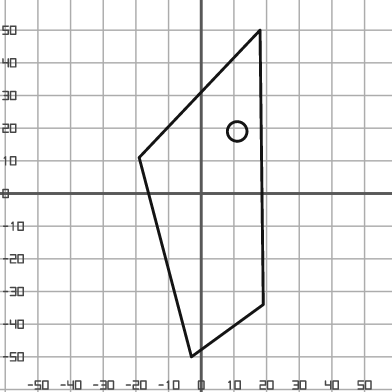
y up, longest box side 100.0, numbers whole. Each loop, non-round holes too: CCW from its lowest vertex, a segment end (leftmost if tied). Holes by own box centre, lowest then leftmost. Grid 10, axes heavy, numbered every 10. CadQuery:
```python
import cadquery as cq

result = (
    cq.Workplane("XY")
    .moveTo(-3.0, -50.0)
    .lineTo(19.0, -34.0)
    .lineTo(18.0, 50.0)
    .lineTo(-19.0, 11.0)
    .close()
    .moveTo(11.0, 19.0)
    .circle(3.0)
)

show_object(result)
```